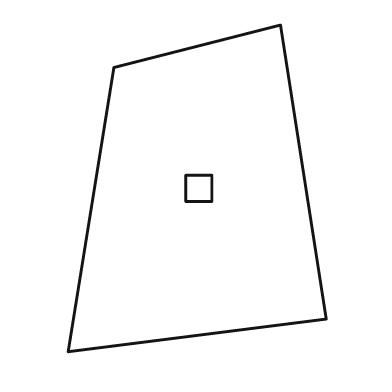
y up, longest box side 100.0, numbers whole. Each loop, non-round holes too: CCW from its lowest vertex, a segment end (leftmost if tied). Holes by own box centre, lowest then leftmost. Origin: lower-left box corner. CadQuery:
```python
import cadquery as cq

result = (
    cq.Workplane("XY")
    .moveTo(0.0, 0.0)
    .lineTo(79.0, 10.0)
    .lineTo(65.0, 100.0)
    .lineTo(14.0, 87.0)
    .close()
    .moveTo(36.0, 46.0)
    .lineTo(44.0, 46.0)
    .lineTo(44.0, 54.0)
    .lineTo(36.0, 54.0)
    .close()
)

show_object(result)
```